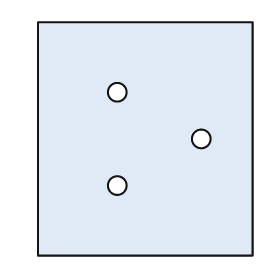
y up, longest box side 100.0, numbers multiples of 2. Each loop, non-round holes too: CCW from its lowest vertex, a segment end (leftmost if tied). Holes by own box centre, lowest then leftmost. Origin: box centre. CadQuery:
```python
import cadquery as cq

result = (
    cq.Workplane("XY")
    .moveTo(-46.0, -50.0)
    .lineTo(46.0, -50.0)
    .lineTo(46.0, 50.0)
    .lineTo(-46.0, 50.0)
    .close()
    .moveTo(-12.0, -20.0)
    .circle(4.0)
    .moveTo(24.0, 0.0)
    .circle(4.0)
    .moveTo(-12.0, 20.0)
    .circle(4.0)
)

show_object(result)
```